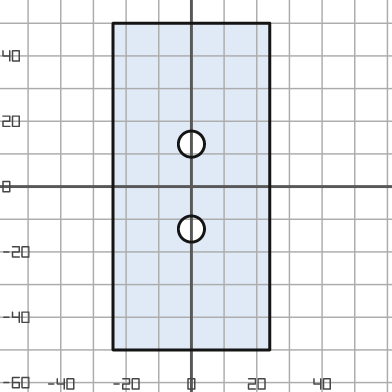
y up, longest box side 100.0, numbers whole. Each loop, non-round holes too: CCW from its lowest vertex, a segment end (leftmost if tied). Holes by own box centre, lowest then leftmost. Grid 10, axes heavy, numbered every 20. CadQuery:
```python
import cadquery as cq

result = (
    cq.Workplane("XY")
    .moveTo(-24.0, -50.0)
    .lineTo(24.0, -50.0)
    .lineTo(24.0, 50.0)
    .lineTo(-24.0, 50.0)
    .close()
    .moveTo(0.0, -13.0)
    .circle(4.0)
    .moveTo(0.0, 13.0)
    .circle(4.0)
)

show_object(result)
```